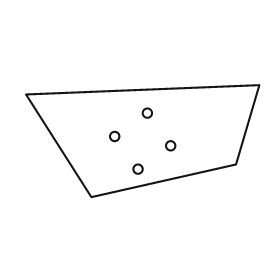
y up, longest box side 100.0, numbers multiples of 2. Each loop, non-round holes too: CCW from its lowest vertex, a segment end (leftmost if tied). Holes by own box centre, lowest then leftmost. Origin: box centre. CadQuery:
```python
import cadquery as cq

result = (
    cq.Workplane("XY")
    .moveTo(-22.0, -24.0)
    .lineTo(40.0, -10.0)
    .lineTo(50.0, 24.0)
    .lineTo(-50.0, 20.0)
    .close()
    .moveTo(-2.0, -12.0)
    .circle(2.0)
    .moveTo(12.0, -2.0)
    .circle(2.0)
    .moveTo(-12.0, 2.0)
    .circle(2.0)
    .moveTo(2.0, 12.0)
    .circle(2.0)
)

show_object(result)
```